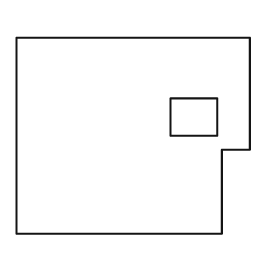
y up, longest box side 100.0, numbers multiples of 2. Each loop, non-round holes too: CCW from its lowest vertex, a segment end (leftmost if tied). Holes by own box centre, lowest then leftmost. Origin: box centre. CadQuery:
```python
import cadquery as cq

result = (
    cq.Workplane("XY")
    .moveTo(-50.0, -42.0)
    .lineTo(38.0, -42.0)
    .lineTo(38.0, -6.0)
    .lineTo(50.0, -6.0)
    .lineTo(50.0, 42.0)
    .lineTo(-50.0, 42.0)
    .close()
    .moveTo(16.0, 0.0)
    .lineTo(36.0, 0.0)
    .lineTo(36.0, 16.0)
    .lineTo(16.0, 16.0)
    .close()
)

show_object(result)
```